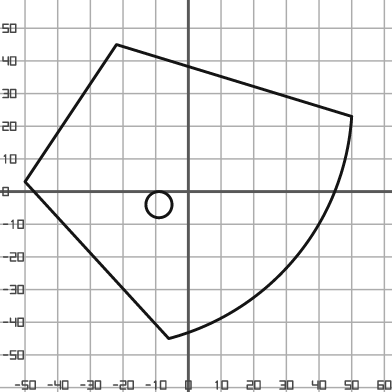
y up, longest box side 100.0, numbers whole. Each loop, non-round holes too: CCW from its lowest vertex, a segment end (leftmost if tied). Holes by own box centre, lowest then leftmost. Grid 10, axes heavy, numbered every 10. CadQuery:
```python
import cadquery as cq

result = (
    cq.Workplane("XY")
    .moveTo(-6.0, -45.0)
    .threePointArc((33.0, -20.0), (50.0, 23.0))
    .lineTo(-22.0, 45.0)
    .lineTo(-50.0, 3.0)
    .close()
    .moveTo(-9.0, -4.0)
    .circle(4.0)
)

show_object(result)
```